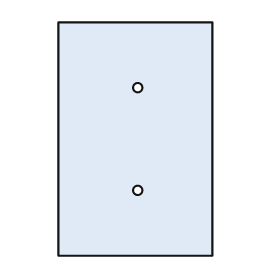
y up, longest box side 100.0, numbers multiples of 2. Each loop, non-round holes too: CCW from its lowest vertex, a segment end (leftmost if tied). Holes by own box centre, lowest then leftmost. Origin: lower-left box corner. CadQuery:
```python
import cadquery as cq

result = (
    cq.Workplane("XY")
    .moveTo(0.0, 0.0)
    .lineTo(66.0, 0.0)
    .lineTo(66.0, 100.0)
    .lineTo(0.0, 100.0)
    .close()
    .moveTo(34.0, 28.0)
    .circle(2.0)
    .moveTo(34.0, 72.0)
    .circle(2.0)
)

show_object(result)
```